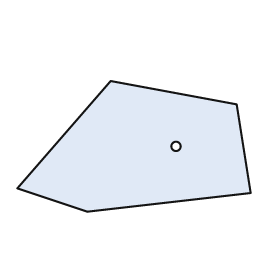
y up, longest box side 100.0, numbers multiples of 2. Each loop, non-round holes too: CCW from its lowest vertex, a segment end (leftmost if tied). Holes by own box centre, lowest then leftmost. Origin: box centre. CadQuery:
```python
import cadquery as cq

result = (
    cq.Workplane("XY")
    .moveTo(-20.0, -28.0)
    .lineTo(50.0, -20.0)
    .lineTo(44.0, 18.0)
    .lineTo(-10.0, 28.0)
    .lineTo(-50.0, -18.0)
    .close()
    .moveTo(18.0, 0.0)
    .circle(2.0)
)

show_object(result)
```